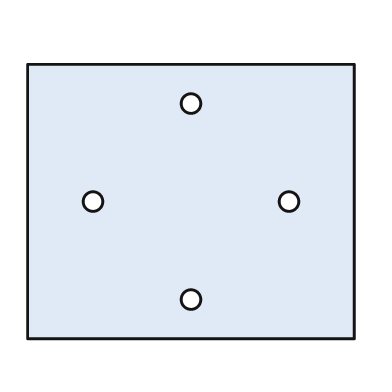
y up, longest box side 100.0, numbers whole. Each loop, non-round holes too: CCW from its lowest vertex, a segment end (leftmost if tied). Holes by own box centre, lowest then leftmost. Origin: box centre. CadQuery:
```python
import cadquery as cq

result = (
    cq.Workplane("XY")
    .moveTo(-50.0, -42.0)
    .lineTo(50.0, -42.0)
    .lineTo(50.0, 42.0)
    .lineTo(-50.0, 42.0)
    .close()
    .moveTo(0.0, -30.0)
    .circle(3.0)
    .moveTo(-30.0, 0.0)
    .circle(3.0)
    .moveTo(30.0, 0.0)
    .circle(3.0)
    .moveTo(0.0, 30.0)
    .circle(3.0)
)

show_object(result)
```